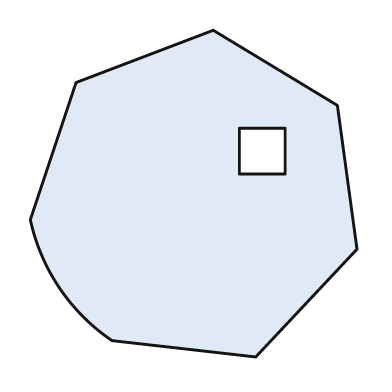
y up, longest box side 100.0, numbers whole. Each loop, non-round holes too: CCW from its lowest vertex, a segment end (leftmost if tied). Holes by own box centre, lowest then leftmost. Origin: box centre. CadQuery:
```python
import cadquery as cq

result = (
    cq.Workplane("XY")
    .moveTo(19.0, -50.0)
    .lineTo(50.0, -17.0)
    .lineTo(44.0, 27.0)
    .lineTo(6.0, 50.0)
    .lineTo(-36.0, 34.0)
    .lineTo(-50.0, -8.0)
    .threePointArc((-41.0, -29.0), (-25.0, -45.0))
    .close()
    .moveTo(14.0, 6.0)
    .lineTo(28.0, 6.0)
    .lineTo(28.0, 20.0)
    .lineTo(14.0, 20.0)
    .close()
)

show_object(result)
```